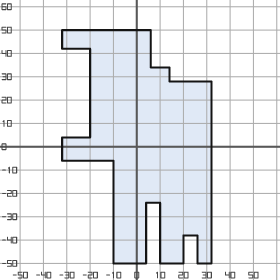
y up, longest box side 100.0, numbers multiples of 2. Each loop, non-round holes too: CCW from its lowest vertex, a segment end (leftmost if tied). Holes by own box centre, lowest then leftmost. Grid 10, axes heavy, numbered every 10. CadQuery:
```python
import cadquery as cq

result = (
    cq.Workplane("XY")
    .moveTo(-10.0, -50.0)
    .lineTo(4.0, -50.0)
    .lineTo(4.0, -24.0)
    .lineTo(10.0, -24.0)
    .lineTo(10.0, -50.0)
    .lineTo(20.0, -50.0)
    .lineTo(20.0, -38.0)
    .lineTo(26.0, -38.0)
    .lineTo(26.0, -50.0)
    .lineTo(32.0, -50.0)
    .lineTo(32.0, 28.0)
    .lineTo(14.0, 28.0)
    .lineTo(14.0, 34.0)
    .lineTo(6.0, 34.0)
    .lineTo(6.0, 50.0)
    .lineTo(-32.0, 50.0)
    .lineTo(-32.0, 42.0)
    .lineTo(-20.0, 42.0)
    .lineTo(-20.0, 4.0)
    .lineTo(-32.0, 4.0)
    .lineTo(-32.0, -6.0)
    .lineTo(-10.0, -6.0)
    .close()
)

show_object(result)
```